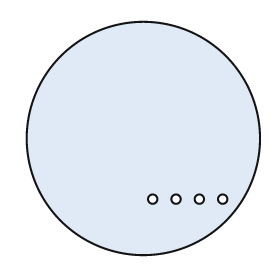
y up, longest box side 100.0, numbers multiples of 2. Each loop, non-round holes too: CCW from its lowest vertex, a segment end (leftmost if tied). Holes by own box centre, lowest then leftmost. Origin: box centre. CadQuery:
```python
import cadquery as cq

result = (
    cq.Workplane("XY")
    .moveTo(0.0, 0.0)
    .circle(50.0)
    .moveTo(4.0, -26.0)
    .circle(2.0)
    .moveTo(14.0, -26.0)
    .circle(2.0)
    .moveTo(24.0, -26.0)
    .circle(2.0)
    .moveTo(34.0, -26.0)
    .circle(2.0)
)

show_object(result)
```